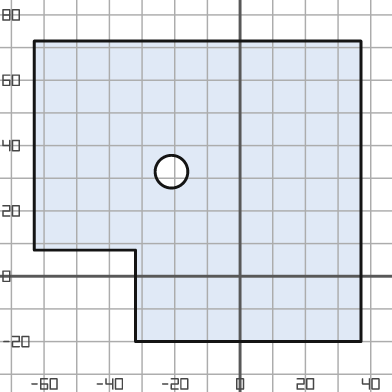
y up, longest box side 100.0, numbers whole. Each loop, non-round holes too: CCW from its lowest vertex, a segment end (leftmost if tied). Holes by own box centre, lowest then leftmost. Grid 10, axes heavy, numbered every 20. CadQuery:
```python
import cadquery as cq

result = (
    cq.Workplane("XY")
    .moveTo(-32.0, -20.0)
    .lineTo(37.0, -20.0)
    .lineTo(37.0, 72.0)
    .lineTo(-63.0, 72.0)
    .lineTo(-63.0, 8.0)
    .lineTo(-32.0, 8.0)
    .close()
    .moveTo(-21.0, 32.0)
    .circle(5.0)
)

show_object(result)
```